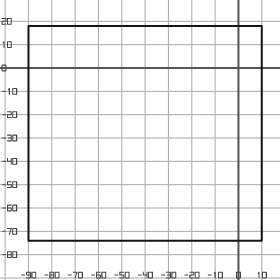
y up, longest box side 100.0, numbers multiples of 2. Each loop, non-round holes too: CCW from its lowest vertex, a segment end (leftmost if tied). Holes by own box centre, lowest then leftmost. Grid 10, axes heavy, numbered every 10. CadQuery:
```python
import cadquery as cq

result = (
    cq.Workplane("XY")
    .moveTo(-90.0, -74.0)
    .lineTo(10.0, -74.0)
    .lineTo(10.0, 18.0)
    .lineTo(-90.0, 18.0)
    .close()
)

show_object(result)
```